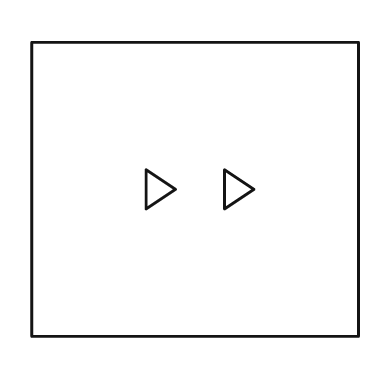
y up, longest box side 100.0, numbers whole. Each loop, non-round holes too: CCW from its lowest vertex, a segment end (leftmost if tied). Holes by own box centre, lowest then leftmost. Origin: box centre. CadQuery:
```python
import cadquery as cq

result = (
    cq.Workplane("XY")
    .moveTo(-50.0, -45.0)
    .lineTo(50.0, -45.0)
    .lineTo(50.0, 45.0)
    .lineTo(-50.0, 45.0)
    .close()
    .moveTo(-15.0, -6.0)
    .lineTo(-6.0, 0.0)
    .lineTo(-15.0, 6.0)
    .close()
    .moveTo(9.0, -6.0)
    .lineTo(18.0, 0.0)
    .lineTo(9.0, 6.0)
    .close()
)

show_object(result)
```